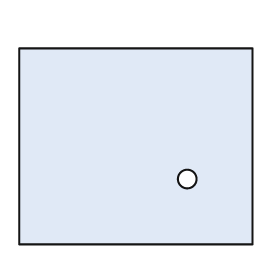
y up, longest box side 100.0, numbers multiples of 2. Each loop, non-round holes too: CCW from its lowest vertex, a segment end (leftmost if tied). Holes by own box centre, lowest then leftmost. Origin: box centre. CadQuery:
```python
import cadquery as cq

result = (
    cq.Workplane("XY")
    .moveTo(-50.0, -42.0)
    .lineTo(50.0, -42.0)
    .lineTo(50.0, 42.0)
    .lineTo(-50.0, 42.0)
    .close()
    .moveTo(22.0, -14.0)
    .circle(4.0)
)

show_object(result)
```